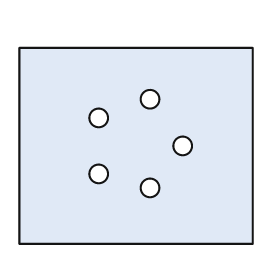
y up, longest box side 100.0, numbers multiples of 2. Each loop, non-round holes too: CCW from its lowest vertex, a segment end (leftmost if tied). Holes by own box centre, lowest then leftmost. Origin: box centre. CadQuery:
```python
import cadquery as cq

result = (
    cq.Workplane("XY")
    .moveTo(-50.0, -42.0)
    .lineTo(50.0, -42.0)
    .lineTo(50.0, 42.0)
    .lineTo(-50.0, 42.0)
    .close()
    .moveTo(6.0, -18.0)
    .circle(4.0)
    .moveTo(-16.0, -12.0)
    .circle(4.0)
    .moveTo(20.0, 0.0)
    .circle(4.0)
    .moveTo(-16.0, 12.0)
    .circle(4.0)
    .moveTo(6.0, 20.0)
    .circle(4.0)
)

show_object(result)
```